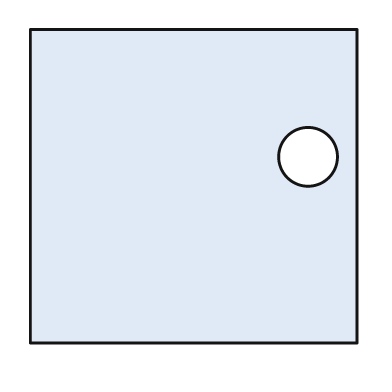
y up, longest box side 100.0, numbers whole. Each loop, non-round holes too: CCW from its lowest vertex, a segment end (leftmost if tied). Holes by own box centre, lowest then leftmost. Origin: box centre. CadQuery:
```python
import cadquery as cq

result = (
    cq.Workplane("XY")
    .moveTo(-50.0, -48.0)
    .lineTo(50.0, -48.0)
    .lineTo(50.0, 48.0)
    .lineTo(-50.0, 48.0)
    .close()
    .moveTo(35.0, 9.0)
    .circle(9.0)
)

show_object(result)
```